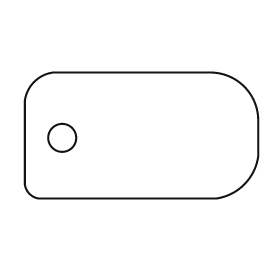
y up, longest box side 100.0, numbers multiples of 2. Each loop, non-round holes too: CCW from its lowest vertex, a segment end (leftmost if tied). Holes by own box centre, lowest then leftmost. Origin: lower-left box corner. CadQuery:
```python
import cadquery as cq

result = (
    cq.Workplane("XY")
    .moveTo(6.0, 0.0)
    .lineTo(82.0, 0.0)
    .threePointArc((94.0, 6.0), (100.0, 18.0))
    .lineTo(100.0, 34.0)
    .threePointArc((94.0, 48.0), (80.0, 54.0))
    .lineTo(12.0, 54.0)
    .threePointArc((4.0, 50.0), (0.0, 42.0))
    .lineTo(0.0, 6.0)
    .threePointArc((2.0, 2.0), (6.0, 0.0))
    .close()
    .moveTo(16.0, 26.0)
    .circle(6.0)
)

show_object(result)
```